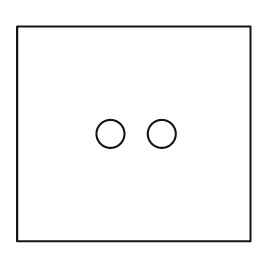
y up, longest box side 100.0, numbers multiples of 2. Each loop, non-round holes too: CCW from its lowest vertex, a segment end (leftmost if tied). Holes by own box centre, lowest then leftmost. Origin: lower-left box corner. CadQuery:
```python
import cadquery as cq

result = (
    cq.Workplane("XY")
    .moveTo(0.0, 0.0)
    .lineTo(100.0, 0.0)
    .lineTo(100.0, 92.0)
    .lineTo(0.0, 92.0)
    .close()
    .moveTo(40.0, 46.0)
    .circle(6.0)
    .moveTo(62.0, 46.0)
    .circle(6.0)
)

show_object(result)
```